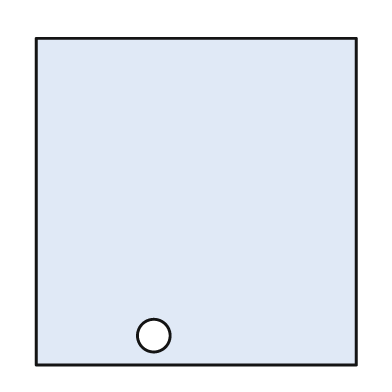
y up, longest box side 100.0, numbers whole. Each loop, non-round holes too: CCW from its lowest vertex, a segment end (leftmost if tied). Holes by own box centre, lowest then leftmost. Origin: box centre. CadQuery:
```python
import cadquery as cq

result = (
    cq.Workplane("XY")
    .moveTo(-49.0, -50.0)
    .lineTo(49.0, -50.0)
    .lineTo(49.0, 50.0)
    .lineTo(-49.0, 50.0)
    .close()
    .moveTo(-13.0, -41.0)
    .circle(5.0)
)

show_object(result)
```